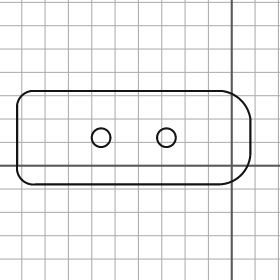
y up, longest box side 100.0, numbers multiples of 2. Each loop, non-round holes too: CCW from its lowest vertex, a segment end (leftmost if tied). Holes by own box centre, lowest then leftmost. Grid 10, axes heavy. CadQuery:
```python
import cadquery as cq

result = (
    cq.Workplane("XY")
    .moveTo(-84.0, -8.0)
    .lineTo(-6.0, -8.0)
    .threePointArc((4.0, -4.0), (8.0, 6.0))
    .lineTo(8.0, 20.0)
    .threePointArc((4.0, 28.0), (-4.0, 32.0))
    .lineTo(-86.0, 32.0)
    .threePointArc((-90.0, 30.0), (-92.0, 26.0))
    .lineTo(-92.0, 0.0)
    .threePointArc((-90.0, -6.0), (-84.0, -8.0))
    .close()
    .moveTo(-56.0, 12.0)
    .circle(4.0)
    .moveTo(-28.0, 12.0)
    .circle(4.0)
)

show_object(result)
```